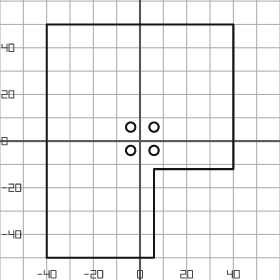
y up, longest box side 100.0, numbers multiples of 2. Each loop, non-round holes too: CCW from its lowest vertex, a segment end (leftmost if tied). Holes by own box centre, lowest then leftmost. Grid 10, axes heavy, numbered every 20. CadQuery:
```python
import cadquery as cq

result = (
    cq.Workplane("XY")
    .moveTo(-40.0, -50.0)
    .lineTo(6.0, -50.0)
    .lineTo(6.0, -12.0)
    .lineTo(40.0, -12.0)
    .lineTo(40.0, 50.0)
    .lineTo(-40.0, 50.0)
    .close()
    .moveTo(-4.0, -4.0)
    .circle(2.0)
    .moveTo(6.0, -4.0)
    .circle(2.0)
    .moveTo(-4.0, 6.0)
    .circle(2.0)
    .moveTo(6.0, 6.0)
    .circle(2.0)
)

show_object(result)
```